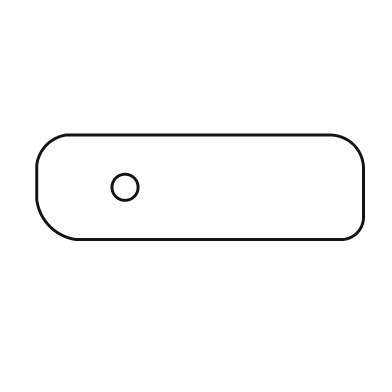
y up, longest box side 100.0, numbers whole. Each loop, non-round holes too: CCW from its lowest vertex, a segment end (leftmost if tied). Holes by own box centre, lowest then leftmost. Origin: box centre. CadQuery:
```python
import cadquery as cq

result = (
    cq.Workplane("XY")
    .moveTo(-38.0, -16.0)
    .lineTo(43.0, -16.0)
    .threePointArc((48.0, -14.0), (50.0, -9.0))
    .lineTo(50.0, 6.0)
    .threePointArc((47.0, 13.0), (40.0, 16.0))
    .lineTo(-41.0, 16.0)
    .threePointArc((-47.0, 13.0), (-50.0, 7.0))
    .lineTo(-50.0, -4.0)
    .threePointArc((-46.0, -12.0), (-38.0, -16.0))
    .close()
    .moveTo(-23.0, 0.0)
    .circle(4.0)
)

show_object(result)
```